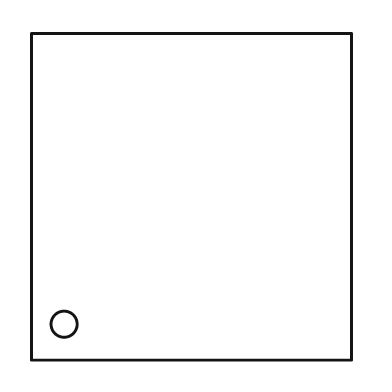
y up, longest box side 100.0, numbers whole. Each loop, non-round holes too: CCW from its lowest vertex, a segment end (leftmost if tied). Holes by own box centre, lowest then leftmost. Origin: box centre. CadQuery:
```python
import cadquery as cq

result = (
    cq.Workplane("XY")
    .moveTo(-49.0, -50.0)
    .lineTo(49.0, -50.0)
    .lineTo(49.0, 50.0)
    .lineTo(-49.0, 50.0)
    .close()
    .moveTo(-39.0, -39.0)
    .circle(4.0)
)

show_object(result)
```